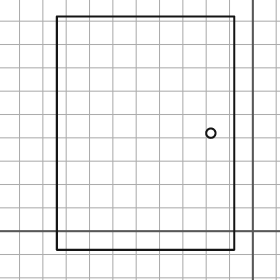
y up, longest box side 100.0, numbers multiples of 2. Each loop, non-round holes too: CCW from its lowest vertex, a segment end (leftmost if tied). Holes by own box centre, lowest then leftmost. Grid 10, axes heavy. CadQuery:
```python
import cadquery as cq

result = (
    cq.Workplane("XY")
    .moveTo(-84.0, -8.0)
    .lineTo(-8.0, -8.0)
    .lineTo(-8.0, 92.0)
    .lineTo(-84.0, 92.0)
    .close()
    .moveTo(-18.0, 42.0)
    .circle(2.0)
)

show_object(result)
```